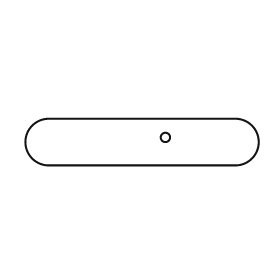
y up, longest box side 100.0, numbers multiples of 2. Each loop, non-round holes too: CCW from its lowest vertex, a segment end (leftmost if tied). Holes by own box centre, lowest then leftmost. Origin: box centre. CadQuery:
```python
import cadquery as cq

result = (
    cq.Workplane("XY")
    .moveTo(-40.0, -10.0)
    .lineTo(40.0, -10.0)
    .threePointArc((50.0, 0.0), (40.0, 10.0))
    .lineTo(-40.0, 10.0)
    .threePointArc((-50.0, 0.0), (-40.0, -10.0))
    .close()
    .moveTo(10.0, 2.0)
    .circle(2.0)
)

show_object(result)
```